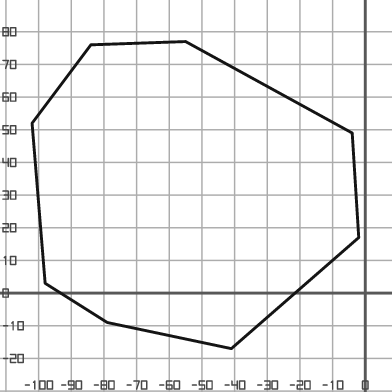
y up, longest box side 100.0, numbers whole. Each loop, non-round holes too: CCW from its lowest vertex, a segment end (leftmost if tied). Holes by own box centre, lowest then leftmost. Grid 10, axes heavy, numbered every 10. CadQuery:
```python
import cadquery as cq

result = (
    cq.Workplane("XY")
    .moveTo(-41.0, -17.0)
    .lineTo(-2.0, 17.0)
    .lineTo(-4.0, 49.0)
    .lineTo(-55.0, 77.0)
    .lineTo(-84.0, 76.0)
    .lineTo(-102.0, 52.0)
    .lineTo(-98.0, 3.0)
    .lineTo(-79.0, -9.0)
    .close()
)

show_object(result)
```